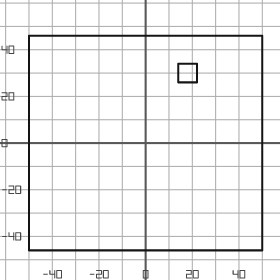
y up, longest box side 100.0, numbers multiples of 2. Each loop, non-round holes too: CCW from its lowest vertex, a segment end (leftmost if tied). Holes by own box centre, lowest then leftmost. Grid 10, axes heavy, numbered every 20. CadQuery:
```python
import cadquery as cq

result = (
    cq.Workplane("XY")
    .moveTo(-50.0, -46.0)
    .lineTo(50.0, -46.0)
    .lineTo(50.0, 46.0)
    .lineTo(-50.0, 46.0)
    .close()
    .moveTo(14.0, 26.0)
    .lineTo(22.0, 26.0)
    .lineTo(22.0, 34.0)
    .lineTo(14.0, 34.0)
    .close()
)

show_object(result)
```